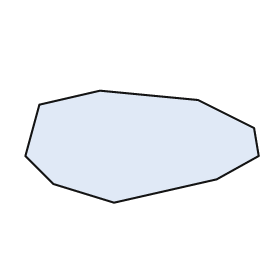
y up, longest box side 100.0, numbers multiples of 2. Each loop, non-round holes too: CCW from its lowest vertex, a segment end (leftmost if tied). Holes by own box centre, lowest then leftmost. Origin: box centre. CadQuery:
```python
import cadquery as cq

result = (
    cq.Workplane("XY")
    .moveTo(-12.0, -24.0)
    .lineTo(32.0, -14.0)
    .lineTo(50.0, -4.0)
    .lineTo(48.0, 8.0)
    .lineTo(24.0, 20.0)
    .lineTo(-18.0, 24.0)
    .lineTo(-44.0, 18.0)
    .lineTo(-50.0, -4.0)
    .lineTo(-38.0, -16.0)
    .close()
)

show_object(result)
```